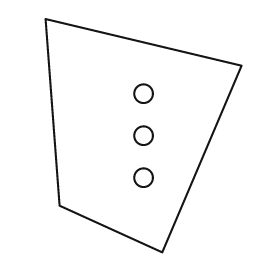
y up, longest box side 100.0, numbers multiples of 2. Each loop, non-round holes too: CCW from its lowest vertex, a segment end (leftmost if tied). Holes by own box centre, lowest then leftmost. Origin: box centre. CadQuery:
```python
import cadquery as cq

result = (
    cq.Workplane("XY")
    .moveTo(8.0, -50.0)
    .lineTo(42.0, 30.0)
    .lineTo(-42.0, 50.0)
    .lineTo(-36.0, -30.0)
    .close()
    .moveTo(0.0, -18.0)
    .circle(4.0)
    .moveTo(0.0, 0.0)
    .circle(4.0)
    .moveTo(0.0, 18.0)
    .circle(4.0)
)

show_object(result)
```